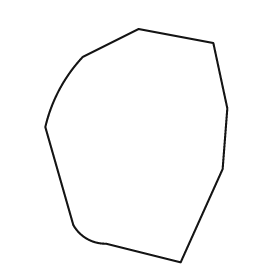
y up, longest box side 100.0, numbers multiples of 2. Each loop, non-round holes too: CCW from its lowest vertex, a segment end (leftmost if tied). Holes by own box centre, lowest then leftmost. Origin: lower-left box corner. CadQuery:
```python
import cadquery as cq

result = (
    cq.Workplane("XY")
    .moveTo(58.0, 0.0)
    .lineTo(76.0, 40.0)
    .lineTo(78.0, 66.0)
    .lineTo(72.0, 94.0)
    .lineTo(40.0, 100.0)
    .lineTo(16.0, 88.0)
    .threePointArc((6.0, 74.0), (0.0, 58.0))
    .lineTo(12.0, 16.0)
    .threePointArc((18.0, 10.0), (26.0, 8.0))
    .close()
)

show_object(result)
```